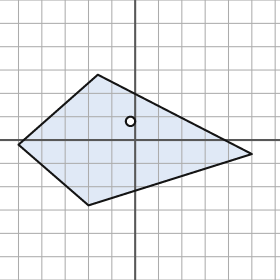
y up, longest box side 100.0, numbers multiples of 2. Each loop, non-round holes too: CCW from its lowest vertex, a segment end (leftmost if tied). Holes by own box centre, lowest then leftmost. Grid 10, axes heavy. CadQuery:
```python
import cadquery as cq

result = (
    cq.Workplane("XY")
    .moveTo(-20.0, -28.0)
    .lineTo(50.0, -6.0)
    .lineTo(-16.0, 28.0)
    .lineTo(-50.0, -2.0)
    .close()
    .moveTo(-2.0, 8.0)
    .circle(2.0)
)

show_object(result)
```